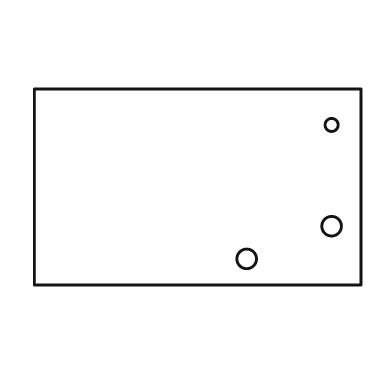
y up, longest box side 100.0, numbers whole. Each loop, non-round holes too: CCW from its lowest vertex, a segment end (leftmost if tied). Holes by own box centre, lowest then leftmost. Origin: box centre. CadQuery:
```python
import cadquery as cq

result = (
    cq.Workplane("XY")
    .moveTo(-50.0, -30.0)
    .lineTo(50.0, -30.0)
    .lineTo(50.0, 30.0)
    .lineTo(-50.0, 30.0)
    .close()
    .moveTo(15.0, -22.0)
    .circle(3.0)
    .moveTo(41.0, -12.0)
    .circle(3.0)
    .moveTo(41.0, 19.0)
    .circle(2.0)
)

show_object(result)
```